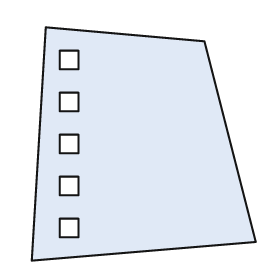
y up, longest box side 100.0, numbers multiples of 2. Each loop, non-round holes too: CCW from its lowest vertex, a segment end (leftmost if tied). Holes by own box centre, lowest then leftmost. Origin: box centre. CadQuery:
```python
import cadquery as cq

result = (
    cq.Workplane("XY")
    .moveTo(-48.0, -50.0)
    .lineTo(48.0, -42.0)
    .lineTo(26.0, 44.0)
    .lineTo(-42.0, 50.0)
    .close()
    .moveTo(-36.0, -40.0)
    .lineTo(-28.0, -40.0)
    .lineTo(-28.0, -32.0)
    .lineTo(-36.0, -32.0)
    .close()
    .moveTo(-36.0, -22.0)
    .lineTo(-28.0, -22.0)
    .lineTo(-28.0, -14.0)
    .lineTo(-36.0, -14.0)
    .close()
    .moveTo(-36.0, -4.0)
    .lineTo(-28.0, -4.0)
    .lineTo(-28.0, 4.0)
    .lineTo(-36.0, 4.0)
    .close()
    .moveTo(-36.0, 14.0)
    .lineTo(-28.0, 14.0)
    .lineTo(-28.0, 22.0)
    .lineTo(-36.0, 22.0)
    .close()
    .moveTo(-36.0, 32.0)
    .lineTo(-28.0, 32.0)
    .lineTo(-28.0, 40.0)
    .lineTo(-36.0, 40.0)
    .close()
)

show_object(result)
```